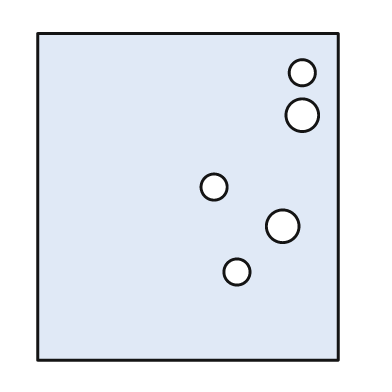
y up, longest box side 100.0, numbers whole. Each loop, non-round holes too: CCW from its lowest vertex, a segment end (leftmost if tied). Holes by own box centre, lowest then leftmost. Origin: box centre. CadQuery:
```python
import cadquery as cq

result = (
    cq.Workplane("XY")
    .moveTo(-46.0, -50.0)
    .lineTo(46.0, -50.0)
    .lineTo(46.0, 50.0)
    .lineTo(-46.0, 50.0)
    .close()
    .moveTo(15.0, -23.0)
    .circle(4.0)
    .moveTo(29.0, -9.0)
    .circle(5.0)
    .moveTo(8.0, 3.0)
    .circle(4.0)
    .moveTo(35.0, 25.0)
    .circle(5.0)
    .moveTo(35.0, 38.0)
    .circle(4.0)
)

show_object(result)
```